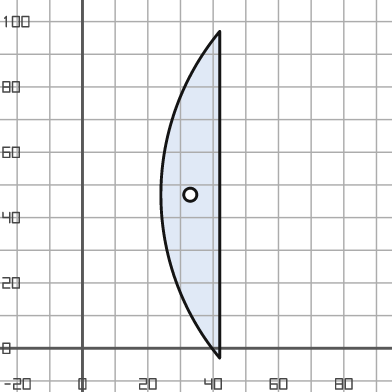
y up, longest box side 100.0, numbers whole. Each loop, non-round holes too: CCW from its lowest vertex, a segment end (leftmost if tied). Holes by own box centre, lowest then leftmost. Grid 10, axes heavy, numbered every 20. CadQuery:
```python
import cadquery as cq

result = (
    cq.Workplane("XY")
    .moveTo(42.0, -3.0)
    .lineTo(42.0, 97.0)
    .threePointArc((24.0, 47.0), (42.0, -3.0))
    .close()
    .moveTo(33.0, 47.0)
    .circle(2.0)
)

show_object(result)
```